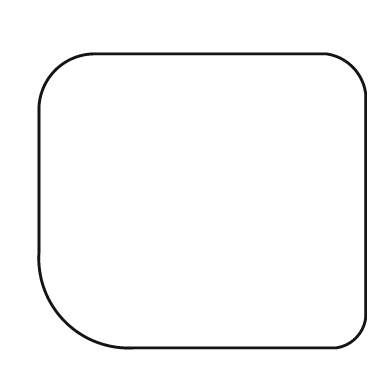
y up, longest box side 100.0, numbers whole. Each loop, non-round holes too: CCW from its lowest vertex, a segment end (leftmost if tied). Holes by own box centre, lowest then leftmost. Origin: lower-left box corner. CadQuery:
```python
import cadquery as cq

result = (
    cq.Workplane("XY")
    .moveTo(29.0, 0.0)
    .lineTo(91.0, 0.0)
    .threePointArc((97.0, 3.0), (100.0, 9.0))
    .lineTo(100.0, 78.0)
    .threePointArc((96.0, 86.0), (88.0, 90.0))
    .lineTo(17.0, 90.0)
    .threePointArc((5.0, 85.0), (0.0, 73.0))
    .lineTo(0.0, 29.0)
    .threePointArc((8.0, 8.0), (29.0, 0.0))
    .close()
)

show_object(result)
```